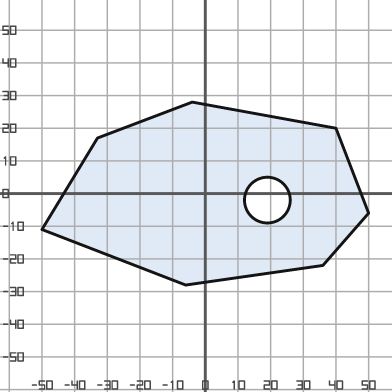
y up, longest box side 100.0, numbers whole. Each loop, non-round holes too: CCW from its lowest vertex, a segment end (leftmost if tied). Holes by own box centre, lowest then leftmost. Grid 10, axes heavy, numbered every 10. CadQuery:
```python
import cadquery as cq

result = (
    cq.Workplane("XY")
    .moveTo(-6.0, -28.0)
    .lineTo(36.0, -22.0)
    .lineTo(50.0, -6.0)
    .lineTo(40.0, 20.0)
    .lineTo(-4.0, 28.0)
    .lineTo(-33.0, 17.0)
    .lineTo(-50.0, -11.0)
    .close()
    .moveTo(19.0, -2.0)
    .circle(7.0)
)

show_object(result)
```